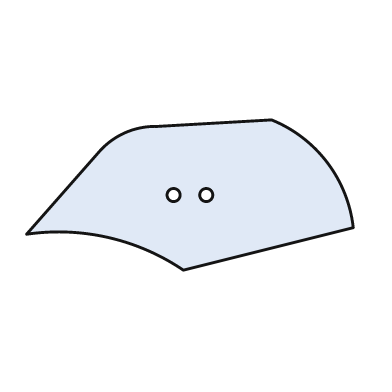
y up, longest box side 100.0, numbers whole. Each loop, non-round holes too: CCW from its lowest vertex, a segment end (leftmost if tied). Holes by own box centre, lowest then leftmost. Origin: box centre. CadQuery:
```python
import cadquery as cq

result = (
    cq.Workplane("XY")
    .moveTo(-2.0, -23.0)
    .lineTo(50.0, -10.0)
    .threePointArc((42.0, 10.0), (25.0, 23.0))
    .lineTo(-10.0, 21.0)
    .threePointArc((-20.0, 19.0), (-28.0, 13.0))
    .lineTo(-50.0, -12.0)
    .threePointArc((-25.0, -13.0), (-2.0, -23.0))
    .close()
    .moveTo(-5.0, 0.0)
    .circle(2.0)
    .moveTo(5.0, 0.0)
    .circle(2.0)
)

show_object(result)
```